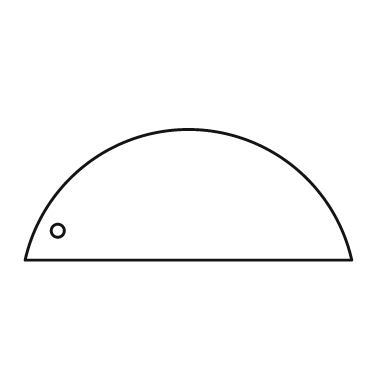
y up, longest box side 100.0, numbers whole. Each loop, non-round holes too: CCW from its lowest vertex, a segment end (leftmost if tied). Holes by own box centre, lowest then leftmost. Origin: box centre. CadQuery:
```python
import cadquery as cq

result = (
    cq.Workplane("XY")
    .moveTo(-50.0, -20.0)
    .lineTo(50.0, -20.0)
    .threePointArc((0.0, 20.0), (-50.0, -20.0))
    .close()
    .moveTo(-40.0, -11.0)
    .circle(2.0)
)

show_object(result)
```